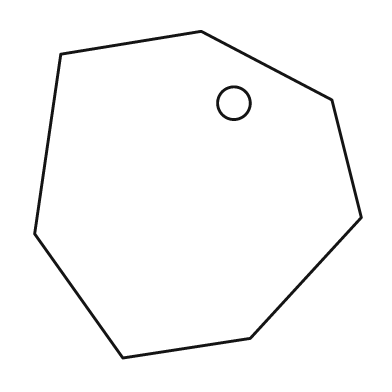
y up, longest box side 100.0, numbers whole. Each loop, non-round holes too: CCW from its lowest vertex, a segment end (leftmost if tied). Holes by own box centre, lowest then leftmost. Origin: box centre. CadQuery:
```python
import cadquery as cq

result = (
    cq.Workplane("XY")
    .moveTo(-23.0, -50.0)
    .lineTo(16.0, -44.0)
    .lineTo(50.0, -7.0)
    .lineTo(41.0, 29.0)
    .lineTo(1.0, 50.0)
    .lineTo(-42.0, 43.0)
    .lineTo(-50.0, -12.0)
    .close()
    .moveTo(11.0, 28.0)
    .circle(5.0)
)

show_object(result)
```